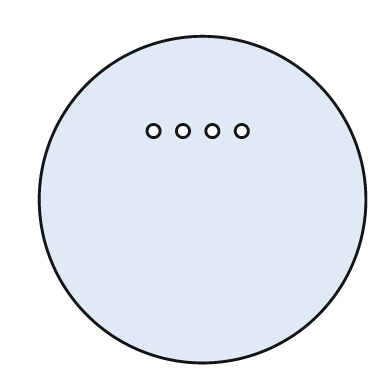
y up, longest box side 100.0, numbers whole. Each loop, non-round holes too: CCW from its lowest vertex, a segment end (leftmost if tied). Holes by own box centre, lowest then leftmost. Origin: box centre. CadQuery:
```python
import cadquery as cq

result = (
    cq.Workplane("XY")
    .moveTo(0.0, 0.0)
    .circle(50.0)
    .moveTo(-15.0, 21.0)
    .circle(2.0)
    .moveTo(-6.0, 21.0)
    .circle(2.0)
    .moveTo(3.0, 21.0)
    .circle(2.0)
    .moveTo(12.0, 21.0)
    .circle(2.0)
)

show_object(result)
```